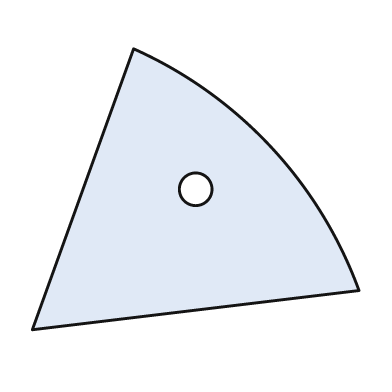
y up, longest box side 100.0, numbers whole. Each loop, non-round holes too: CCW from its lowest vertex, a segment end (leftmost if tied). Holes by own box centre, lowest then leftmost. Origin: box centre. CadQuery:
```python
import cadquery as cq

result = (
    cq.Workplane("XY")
    .moveTo(-50.0, -43.0)
    .lineTo(50.0, -31.0)
    .threePointArc((23.0, 13.0), (-19.0, 43.0))
    .close()
    .moveTo(0.0, 0.0)
    .circle(5.0)
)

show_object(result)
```